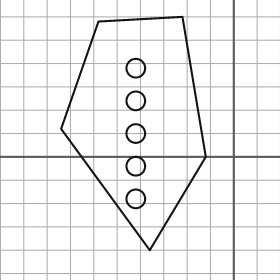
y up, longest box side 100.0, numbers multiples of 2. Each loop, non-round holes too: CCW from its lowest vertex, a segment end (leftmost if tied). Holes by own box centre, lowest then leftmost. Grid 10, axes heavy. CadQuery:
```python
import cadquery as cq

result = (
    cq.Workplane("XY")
    .moveTo(-36.0, -40.0)
    .lineTo(-12.0, 0.0)
    .lineTo(-22.0, 60.0)
    .lineTo(-58.0, 58.0)
    .lineTo(-74.0, 12.0)
    .close()
    .moveTo(-42.0, -18.0)
    .circle(4.0)
    .moveTo(-42.0, -4.0)
    .circle(4.0)
    .moveTo(-42.0, 10.0)
    .circle(4.0)
    .moveTo(-42.0, 24.0)
    .circle(4.0)
    .moveTo(-42.0, 38.0)
    .circle(4.0)
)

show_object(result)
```